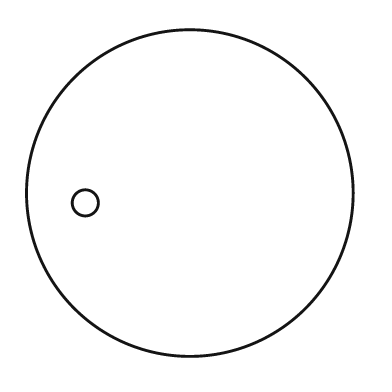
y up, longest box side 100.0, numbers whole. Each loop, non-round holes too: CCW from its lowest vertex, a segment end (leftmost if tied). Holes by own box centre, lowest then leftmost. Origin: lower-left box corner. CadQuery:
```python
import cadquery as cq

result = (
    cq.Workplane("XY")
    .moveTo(50.0, 50.0)
    .circle(50.0)
    .moveTo(18.0, 47.0)
    .circle(4.0)
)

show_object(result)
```